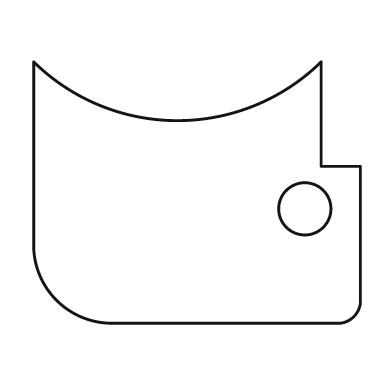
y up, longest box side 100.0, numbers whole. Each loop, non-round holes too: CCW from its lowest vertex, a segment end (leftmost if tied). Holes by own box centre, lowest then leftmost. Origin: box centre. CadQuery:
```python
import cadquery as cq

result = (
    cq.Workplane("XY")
    .moveTo(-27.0, -40.0)
    .lineTo(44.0, -40.0)
    .threePointArc((48.0, -38.0), (50.0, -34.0))
    .lineTo(50.0, 8.0)
    .lineTo(38.0, 8.0)
    .lineTo(38.0, 40.0)
    .threePointArc((-6.0, 22.0), (-50.0, 40.0))
    .lineTo(-50.0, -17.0)
    .threePointArc((-43.0, -33.0), (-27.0, -40.0))
    .close()
    .moveTo(33.0, -5.0)
    .circle(8.0)
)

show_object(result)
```